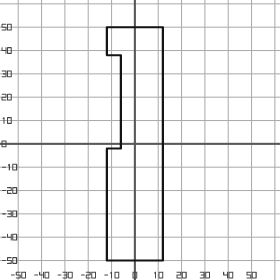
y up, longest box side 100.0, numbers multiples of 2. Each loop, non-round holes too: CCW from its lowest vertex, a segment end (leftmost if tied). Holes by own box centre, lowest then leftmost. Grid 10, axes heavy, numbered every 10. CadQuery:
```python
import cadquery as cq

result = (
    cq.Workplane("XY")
    .moveTo(-12.0, -50.0)
    .lineTo(12.0, -50.0)
    .lineTo(12.0, 50.0)
    .lineTo(-12.0, 50.0)
    .lineTo(-12.0, 38.0)
    .lineTo(-6.0, 38.0)
    .lineTo(-6.0, -2.0)
    .lineTo(-12.0, -2.0)
    .close()
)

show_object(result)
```